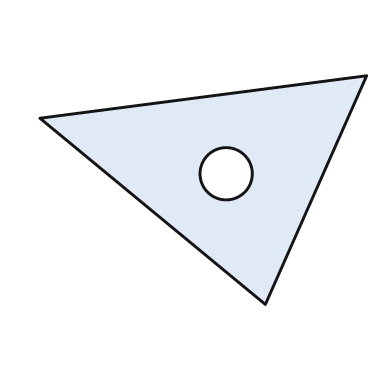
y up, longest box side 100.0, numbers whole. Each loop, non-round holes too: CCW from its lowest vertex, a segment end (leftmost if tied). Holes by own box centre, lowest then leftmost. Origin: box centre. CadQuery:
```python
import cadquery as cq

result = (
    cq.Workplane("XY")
    .moveTo(19.0, -35.0)
    .lineTo(50.0, 35.0)
    .lineTo(-50.0, 22.0)
    .close()
    .moveTo(7.0, 5.0)
    .circle(8.0)
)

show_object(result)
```